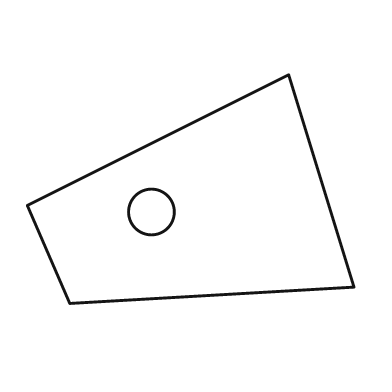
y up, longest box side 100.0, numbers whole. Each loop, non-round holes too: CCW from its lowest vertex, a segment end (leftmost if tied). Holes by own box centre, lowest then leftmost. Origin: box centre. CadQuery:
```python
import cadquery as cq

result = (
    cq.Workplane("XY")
    .moveTo(-37.0, -35.0)
    .lineTo(50.0, -30.0)
    .lineTo(30.0, 35.0)
    .lineTo(-50.0, -5.0)
    .close()
    .moveTo(-12.0, -7.0)
    .circle(7.0)
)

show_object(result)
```